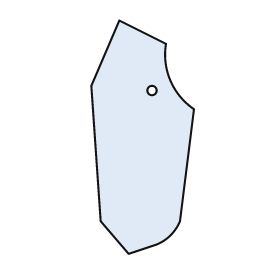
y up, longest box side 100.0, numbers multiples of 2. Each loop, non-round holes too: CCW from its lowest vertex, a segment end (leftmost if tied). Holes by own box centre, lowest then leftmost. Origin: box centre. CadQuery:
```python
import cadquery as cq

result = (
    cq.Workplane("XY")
    .moveTo(-6.0, -50.0)
    .lineTo(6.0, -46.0)
    .threePointArc((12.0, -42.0), (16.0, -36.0))
    .lineTo(22.0, 12.0)
    .threePointArc((12.0, 24.0), (10.0, 40.0))
    .lineTo(-10.0, 50.0)
    .lineTo(-22.0, 22.0)
    .lineTo(-18.0, -36.0)
    .close()
    .moveTo(4.0, 20.0)
    .circle(2.0)
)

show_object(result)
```